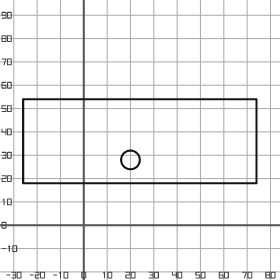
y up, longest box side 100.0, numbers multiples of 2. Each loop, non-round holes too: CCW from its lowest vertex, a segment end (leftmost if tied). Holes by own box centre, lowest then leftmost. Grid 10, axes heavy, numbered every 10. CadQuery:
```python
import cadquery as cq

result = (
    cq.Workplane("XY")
    .moveTo(-26.0, 18.0)
    .lineTo(74.0, 18.0)
    .lineTo(74.0, 54.0)
    .lineTo(-26.0, 54.0)
    .close()
    .moveTo(20.0, 28.0)
    .circle(4.0)
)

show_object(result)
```